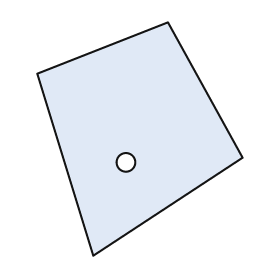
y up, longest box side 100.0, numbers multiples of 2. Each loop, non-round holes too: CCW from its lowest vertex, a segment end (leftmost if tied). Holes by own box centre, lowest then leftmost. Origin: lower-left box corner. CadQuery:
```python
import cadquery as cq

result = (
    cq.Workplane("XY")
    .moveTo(24.0, 0.0)
    .lineTo(88.0, 42.0)
    .lineTo(56.0, 100.0)
    .lineTo(0.0, 78.0)
    .close()
    .moveTo(38.0, 40.0)
    .circle(4.0)
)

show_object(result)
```